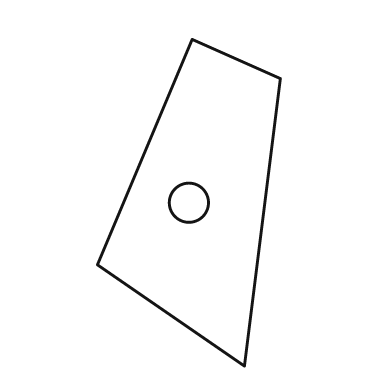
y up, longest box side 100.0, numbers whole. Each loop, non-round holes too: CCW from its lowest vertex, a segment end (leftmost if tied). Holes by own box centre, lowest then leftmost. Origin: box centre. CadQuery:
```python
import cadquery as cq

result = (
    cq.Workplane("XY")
    .moveTo(17.0, -50.0)
    .lineTo(28.0, 38.0)
    .lineTo(1.0, 50.0)
    .lineTo(-28.0, -19.0)
    .close()
    .moveTo(0.0, 0.0)
    .circle(6.0)
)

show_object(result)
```